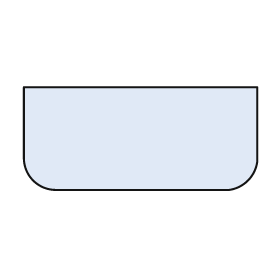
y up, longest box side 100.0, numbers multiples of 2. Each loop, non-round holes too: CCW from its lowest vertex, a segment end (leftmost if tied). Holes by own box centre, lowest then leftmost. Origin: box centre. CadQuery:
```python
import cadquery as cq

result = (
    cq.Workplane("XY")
    .moveTo(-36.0, -22.0)
    .lineTo(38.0, -22.0)
    .threePointArc((46.0, -18.0), (50.0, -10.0))
    .lineTo(50.0, 22.0)
    .lineTo(-50.0, 22.0)
    .lineTo(-50.0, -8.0)
    .threePointArc((-46.0, -18.0), (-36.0, -22.0))
    .close()
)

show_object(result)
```